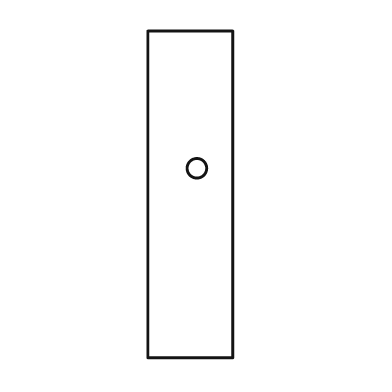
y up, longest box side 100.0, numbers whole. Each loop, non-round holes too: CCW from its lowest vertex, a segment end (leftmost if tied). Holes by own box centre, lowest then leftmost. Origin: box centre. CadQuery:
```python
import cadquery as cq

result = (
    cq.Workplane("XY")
    .moveTo(-13.0, -50.0)
    .lineTo(13.0, -50.0)
    .lineTo(13.0, 50.0)
    .lineTo(-13.0, 50.0)
    .close()
    .moveTo(2.0, 8.0)
    .circle(3.0)
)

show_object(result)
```